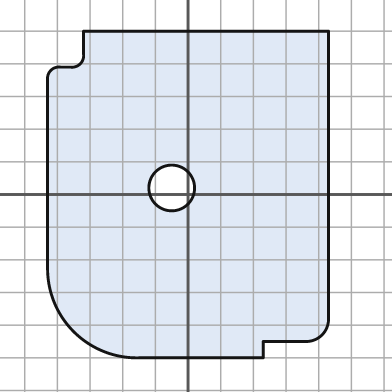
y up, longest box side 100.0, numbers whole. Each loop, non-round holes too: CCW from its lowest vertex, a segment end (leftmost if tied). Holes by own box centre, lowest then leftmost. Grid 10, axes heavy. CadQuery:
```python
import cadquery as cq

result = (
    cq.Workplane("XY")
    .moveTo(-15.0, -50.0)
    .lineTo(23.0, -50.0)
    .lineTo(23.0, -45.0)
    .lineTo(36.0, -45.0)
    .threePointArc((41.0, -43.0), (43.0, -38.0))
    .lineTo(43.0, 50.0)
    .lineTo(-32.0, 50.0)
    .lineTo(-32.0, 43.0)
    .threePointArc((-33.0, 40.0), (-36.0, 39.0))
    .lineTo(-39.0, 39.0)
    .threePointArc((-42.0, 38.0), (-43.0, 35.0))
    .lineTo(-43.0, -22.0)
    .threePointArc((-35.0, -42.0), (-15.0, -50.0))
    .close()
    .moveTo(-5.0, 2.0)
    .circle(7.0)
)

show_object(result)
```